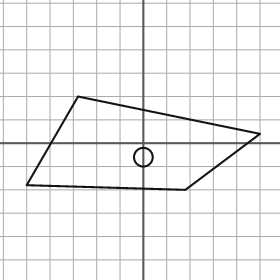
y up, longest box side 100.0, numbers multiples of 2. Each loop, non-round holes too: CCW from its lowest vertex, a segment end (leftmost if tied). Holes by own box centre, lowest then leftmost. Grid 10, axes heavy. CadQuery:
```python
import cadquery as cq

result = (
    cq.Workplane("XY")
    .moveTo(18.0, -20.0)
    .lineTo(50.0, 4.0)
    .lineTo(-28.0, 20.0)
    .lineTo(-50.0, -18.0)
    .close()
    .moveTo(0.0, -6.0)
    .circle(4.0)
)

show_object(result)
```